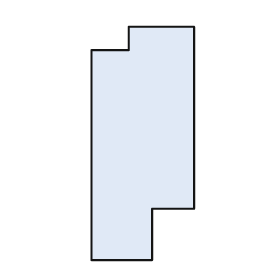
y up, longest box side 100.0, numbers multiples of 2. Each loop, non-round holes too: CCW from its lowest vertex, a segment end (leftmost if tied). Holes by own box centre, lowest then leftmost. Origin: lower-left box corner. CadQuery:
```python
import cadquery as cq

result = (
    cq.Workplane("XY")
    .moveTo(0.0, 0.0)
    .lineTo(26.0, 0.0)
    .lineTo(26.0, 22.0)
    .lineTo(44.0, 22.0)
    .lineTo(44.0, 100.0)
    .lineTo(16.0, 100.0)
    .lineTo(16.0, 90.0)
    .lineTo(0.0, 90.0)
    .close()
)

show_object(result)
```